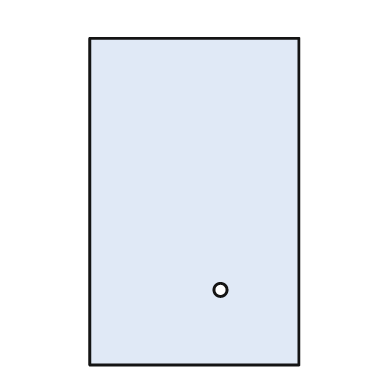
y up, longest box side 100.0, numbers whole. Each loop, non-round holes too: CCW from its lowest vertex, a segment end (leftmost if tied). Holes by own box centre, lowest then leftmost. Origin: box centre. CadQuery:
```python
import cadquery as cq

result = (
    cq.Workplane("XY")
    .moveTo(-32.0, -50.0)
    .lineTo(32.0, -50.0)
    .lineTo(32.0, 50.0)
    .lineTo(-32.0, 50.0)
    .close()
    .moveTo(8.0, -27.0)
    .circle(2.0)
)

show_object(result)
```